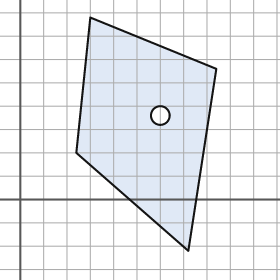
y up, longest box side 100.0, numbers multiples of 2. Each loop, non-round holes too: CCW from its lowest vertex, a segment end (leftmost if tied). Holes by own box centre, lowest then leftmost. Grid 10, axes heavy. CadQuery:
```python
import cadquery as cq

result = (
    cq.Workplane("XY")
    .moveTo(72.0, -22.0)
    .lineTo(84.0, 56.0)
    .lineTo(30.0, 78.0)
    .lineTo(24.0, 20.0)
    .close()
    .moveTo(60.0, 36.0)
    .circle(4.0)
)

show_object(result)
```